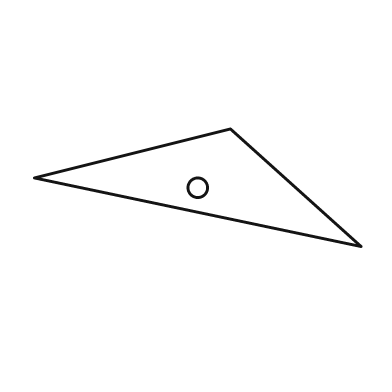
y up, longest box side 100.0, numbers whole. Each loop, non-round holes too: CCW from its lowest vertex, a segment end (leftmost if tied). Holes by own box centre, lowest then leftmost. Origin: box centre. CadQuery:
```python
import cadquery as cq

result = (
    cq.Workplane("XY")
    .moveTo(50.0, -18.0)
    .lineTo(10.0, 18.0)
    .lineTo(-50.0, 3.0)
    .close()
    .moveTo(0.0, 0.0)
    .circle(3.0)
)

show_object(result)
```